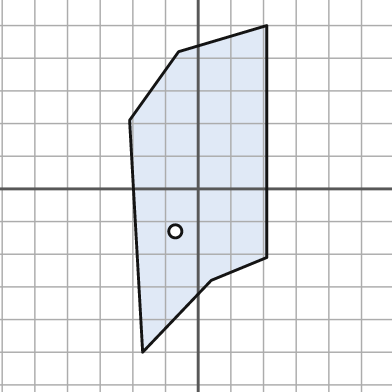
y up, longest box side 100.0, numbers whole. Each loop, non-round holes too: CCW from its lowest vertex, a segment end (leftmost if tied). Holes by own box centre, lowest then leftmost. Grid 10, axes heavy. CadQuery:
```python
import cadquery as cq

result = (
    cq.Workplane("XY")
    .moveTo(-17.0, -50.0)
    .lineTo(4.0, -28.0)
    .lineTo(21.0, -21.0)
    .lineTo(21.0, 50.0)
    .lineTo(-6.0, 42.0)
    .lineTo(-21.0, 21.0)
    .close()
    .moveTo(-7.0, -13.0)
    .circle(2.0)
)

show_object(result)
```